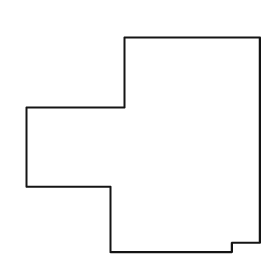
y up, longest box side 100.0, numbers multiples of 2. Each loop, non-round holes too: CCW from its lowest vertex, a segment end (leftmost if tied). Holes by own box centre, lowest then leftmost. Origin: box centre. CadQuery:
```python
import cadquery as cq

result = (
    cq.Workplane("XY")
    .moveTo(-14.0, -46.0)
    .lineTo(38.0, -46.0)
    .lineTo(38.0, -42.0)
    .lineTo(50.0, -42.0)
    .lineTo(50.0, 46.0)
    .lineTo(-8.0, 46.0)
    .lineTo(-8.0, 16.0)
    .lineTo(-50.0, 16.0)
    .lineTo(-50.0, -18.0)
    .lineTo(-14.0, -18.0)
    .close()
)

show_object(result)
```